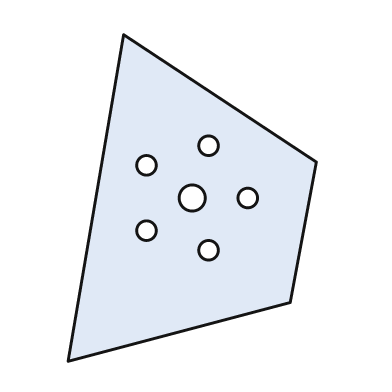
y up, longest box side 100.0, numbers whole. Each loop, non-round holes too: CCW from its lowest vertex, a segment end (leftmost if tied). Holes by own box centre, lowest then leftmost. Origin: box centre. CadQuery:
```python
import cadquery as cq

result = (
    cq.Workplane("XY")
    .moveTo(-38.0, -50.0)
    .lineTo(30.0, -32.0)
    .lineTo(38.0, 11.0)
    .lineTo(-21.0, 50.0)
    .close()
    .moveTo(5.0, -16.0)
    .circle(3.0)
    .moveTo(-14.0, -10.0)
    .circle(3.0)
    .moveTo(0.0, 0.0)
    .circle(4.0)
    .moveTo(17.0, 0.0)
    .circle(3.0)
    .moveTo(-14.0, 10.0)
    .circle(3.0)
    .moveTo(5.0, 16.0)
    .circle(3.0)
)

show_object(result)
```